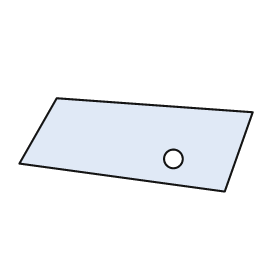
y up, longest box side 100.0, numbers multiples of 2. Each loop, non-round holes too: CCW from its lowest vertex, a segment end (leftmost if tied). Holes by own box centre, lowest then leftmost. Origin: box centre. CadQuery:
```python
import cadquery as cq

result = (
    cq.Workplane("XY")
    .moveTo(38.0, -20.0)
    .lineTo(50.0, 14.0)
    .lineTo(-34.0, 20.0)
    .lineTo(-50.0, -8.0)
    .close()
    .moveTo(16.0, -6.0)
    .circle(4.0)
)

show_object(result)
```